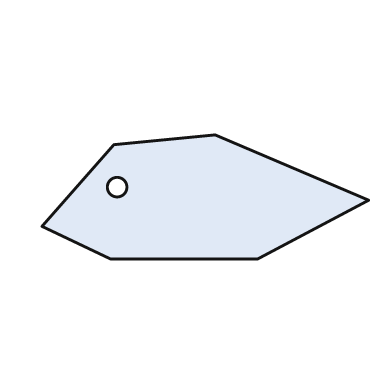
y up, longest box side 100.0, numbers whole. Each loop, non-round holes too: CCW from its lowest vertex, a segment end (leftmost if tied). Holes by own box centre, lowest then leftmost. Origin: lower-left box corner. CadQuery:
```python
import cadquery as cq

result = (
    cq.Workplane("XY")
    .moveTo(21.0, 0.0)
    .lineTo(66.0, 0.0)
    .lineTo(100.0, 18.0)
    .lineTo(53.0, 38.0)
    .lineTo(22.0, 35.0)
    .lineTo(0.0, 10.0)
    .close()
    .moveTo(23.0, 22.0)
    .circle(3.0)
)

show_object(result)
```